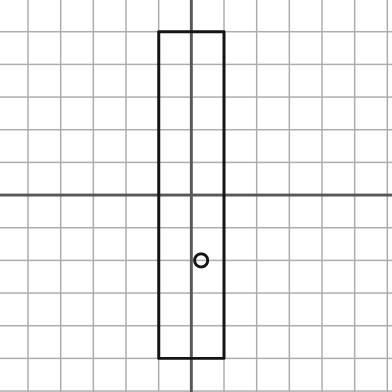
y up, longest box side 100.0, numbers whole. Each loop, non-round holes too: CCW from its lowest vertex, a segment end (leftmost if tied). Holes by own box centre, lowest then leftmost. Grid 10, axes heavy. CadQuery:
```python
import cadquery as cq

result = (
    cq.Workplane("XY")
    .moveTo(-10.0, -50.0)
    .lineTo(10.0, -50.0)
    .lineTo(10.0, 50.0)
    .lineTo(-10.0, 50.0)
    .close()
    .moveTo(3.0, -20.0)
    .circle(2.0)
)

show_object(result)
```